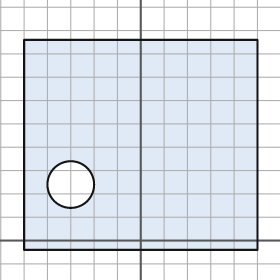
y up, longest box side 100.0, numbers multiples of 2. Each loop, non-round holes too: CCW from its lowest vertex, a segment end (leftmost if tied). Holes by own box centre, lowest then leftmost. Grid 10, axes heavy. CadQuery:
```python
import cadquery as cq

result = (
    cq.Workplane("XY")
    .moveTo(-50.0, -4.0)
    .lineTo(50.0, -4.0)
    .lineTo(50.0, 86.0)
    .lineTo(-50.0, 86.0)
    .close()
    .moveTo(-30.0, 24.0)
    .circle(10.0)
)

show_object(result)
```